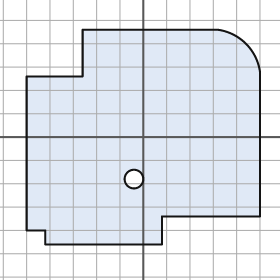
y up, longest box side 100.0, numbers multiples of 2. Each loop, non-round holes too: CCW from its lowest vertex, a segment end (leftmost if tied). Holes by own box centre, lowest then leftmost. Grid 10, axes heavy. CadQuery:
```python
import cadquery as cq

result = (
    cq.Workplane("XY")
    .moveTo(-42.0, -46.0)
    .lineTo(8.0, -46.0)
    .lineTo(8.0, -34.0)
    .lineTo(50.0, -34.0)
    .lineTo(50.0, 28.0)
    .threePointArc((44.0, 40.0), (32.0, 46.0))
    .lineTo(-26.0, 46.0)
    .lineTo(-26.0, 26.0)
    .lineTo(-50.0, 26.0)
    .lineTo(-50.0, -40.0)
    .lineTo(-42.0, -40.0)
    .close()
    .moveTo(-4.0, -18.0)
    .circle(4.0)
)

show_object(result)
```